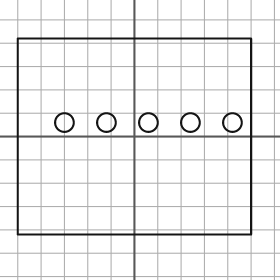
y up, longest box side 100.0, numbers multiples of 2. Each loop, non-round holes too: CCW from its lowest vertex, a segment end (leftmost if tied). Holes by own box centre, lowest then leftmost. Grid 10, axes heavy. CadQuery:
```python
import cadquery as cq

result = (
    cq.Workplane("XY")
    .moveTo(-50.0, -42.0)
    .lineTo(50.0, -42.0)
    .lineTo(50.0, 42.0)
    .lineTo(-50.0, 42.0)
    .close()
    .moveTo(-30.0, 6.0)
    .circle(4.0)
    .moveTo(-12.0, 6.0)
    .circle(4.0)
    .moveTo(6.0, 6.0)
    .circle(4.0)
    .moveTo(24.0, 6.0)
    .circle(4.0)
    .moveTo(42.0, 6.0)
    .circle(4.0)
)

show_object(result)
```